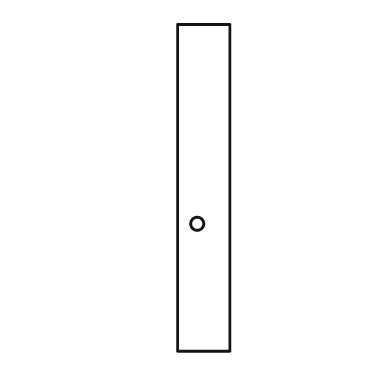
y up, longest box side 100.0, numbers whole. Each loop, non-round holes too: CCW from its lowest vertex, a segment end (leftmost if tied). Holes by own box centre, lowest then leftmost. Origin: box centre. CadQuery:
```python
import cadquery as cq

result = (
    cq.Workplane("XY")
    .moveTo(-8.0, -50.0)
    .lineTo(8.0, -50.0)
    .lineTo(8.0, 50.0)
    .lineTo(-8.0, 50.0)
    .close()
    .moveTo(-2.0, -11.0)
    .circle(2.0)
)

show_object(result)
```